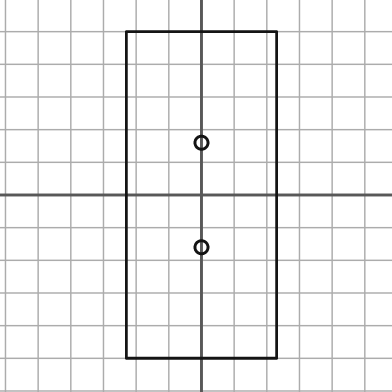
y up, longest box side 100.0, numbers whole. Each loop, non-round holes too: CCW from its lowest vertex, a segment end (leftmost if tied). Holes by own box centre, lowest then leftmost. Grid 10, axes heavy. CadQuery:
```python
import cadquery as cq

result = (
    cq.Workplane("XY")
    .moveTo(-23.0, -50.0)
    .lineTo(23.0, -50.0)
    .lineTo(23.0, 50.0)
    .lineTo(-23.0, 50.0)
    .close()
    .moveTo(0.0, -16.0)
    .circle(2.0)
    .moveTo(0.0, 16.0)
    .circle(2.0)
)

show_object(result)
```